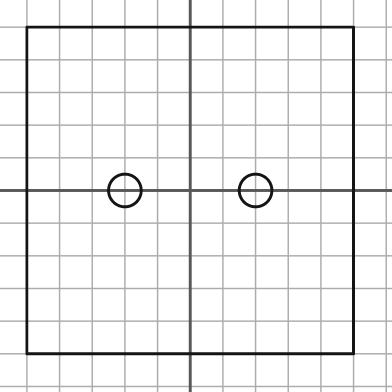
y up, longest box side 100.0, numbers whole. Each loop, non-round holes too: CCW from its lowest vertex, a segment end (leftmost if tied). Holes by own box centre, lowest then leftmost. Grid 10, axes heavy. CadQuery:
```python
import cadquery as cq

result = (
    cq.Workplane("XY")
    .moveTo(-50.0, -50.0)
    .lineTo(50.0, -50.0)
    .lineTo(50.0, 50.0)
    .lineTo(-50.0, 50.0)
    .close()
    .moveTo(-20.0, 0.0)
    .circle(5.0)
    .moveTo(20.0, 0.0)
    .circle(5.0)
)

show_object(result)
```